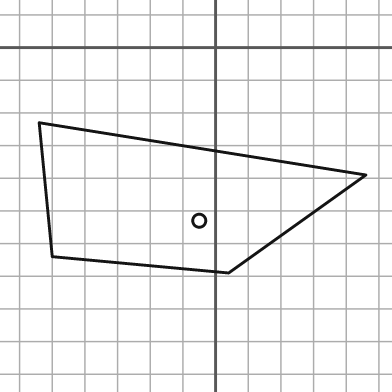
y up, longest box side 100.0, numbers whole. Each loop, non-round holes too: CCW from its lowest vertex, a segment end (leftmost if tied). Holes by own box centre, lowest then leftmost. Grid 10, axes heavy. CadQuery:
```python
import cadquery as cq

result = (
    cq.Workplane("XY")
    .moveTo(4.0, -69.0)
    .lineTo(46.0, -39.0)
    .lineTo(-54.0, -23.0)
    .lineTo(-50.0, -64.0)
    .close()
    .moveTo(-5.0, -53.0)
    .circle(2.0)
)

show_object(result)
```